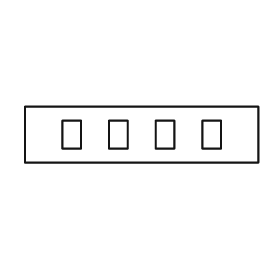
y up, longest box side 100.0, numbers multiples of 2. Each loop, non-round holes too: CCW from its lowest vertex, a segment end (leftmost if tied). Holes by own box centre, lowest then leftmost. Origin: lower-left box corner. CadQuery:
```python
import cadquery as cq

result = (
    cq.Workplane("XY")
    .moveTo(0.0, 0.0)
    .lineTo(100.0, 0.0)
    .lineTo(100.0, 24.0)
    .lineTo(0.0, 24.0)
    .close()
    .moveTo(16.0, 6.0)
    .lineTo(24.0, 6.0)
    .lineTo(24.0, 18.0)
    .lineTo(16.0, 18.0)
    .close()
    .moveTo(36.0, 6.0)
    .lineTo(44.0, 6.0)
    .lineTo(44.0, 18.0)
    .lineTo(36.0, 18.0)
    .close()
    .moveTo(56.0, 6.0)
    .lineTo(64.0, 6.0)
    .lineTo(64.0, 18.0)
    .lineTo(56.0, 18.0)
    .close()
    .moveTo(76.0, 6.0)
    .lineTo(84.0, 6.0)
    .lineTo(84.0, 18.0)
    .lineTo(76.0, 18.0)
    .close()
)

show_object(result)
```